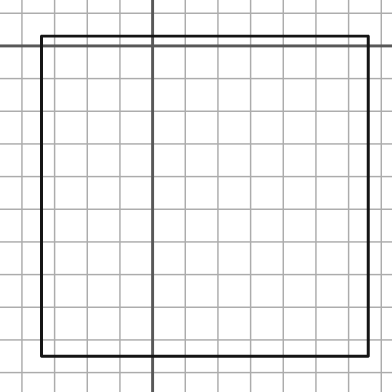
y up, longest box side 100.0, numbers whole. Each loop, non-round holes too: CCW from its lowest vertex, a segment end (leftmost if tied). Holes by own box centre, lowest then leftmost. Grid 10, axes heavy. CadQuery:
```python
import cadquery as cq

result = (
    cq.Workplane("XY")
    .moveTo(-34.0, -95.0)
    .lineTo(66.0, -95.0)
    .lineTo(66.0, 3.0)
    .lineTo(-34.0, 3.0)
    .close()
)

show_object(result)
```